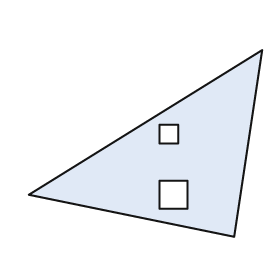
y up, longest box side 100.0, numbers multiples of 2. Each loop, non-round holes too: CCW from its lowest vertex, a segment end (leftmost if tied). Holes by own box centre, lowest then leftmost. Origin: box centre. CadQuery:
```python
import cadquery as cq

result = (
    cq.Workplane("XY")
    .moveTo(38.0, -40.0)
    .lineTo(50.0, 40.0)
    .lineTo(-50.0, -22.0)
    .close()
    .moveTo(6.0, -28.0)
    .lineTo(18.0, -28.0)
    .lineTo(18.0, -16.0)
    .lineTo(6.0, -16.0)
    .close()
    .moveTo(6.0, 0.0)
    .lineTo(14.0, 0.0)
    .lineTo(14.0, 8.0)
    .lineTo(6.0, 8.0)
    .close()
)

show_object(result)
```